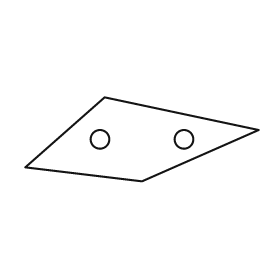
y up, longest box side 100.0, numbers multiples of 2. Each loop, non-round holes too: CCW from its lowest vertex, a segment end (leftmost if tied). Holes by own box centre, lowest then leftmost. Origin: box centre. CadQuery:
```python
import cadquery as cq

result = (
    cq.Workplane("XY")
    .moveTo(0.0, -18.0)
    .lineTo(50.0, 4.0)
    .lineTo(-16.0, 18.0)
    .lineTo(-50.0, -12.0)
    .close()
    .moveTo(-18.0, 0.0)
    .circle(4.0)
    .moveTo(18.0, 0.0)
    .circle(4.0)
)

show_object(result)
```